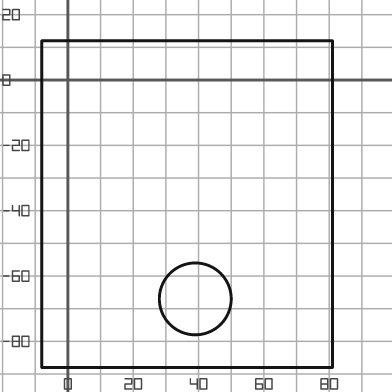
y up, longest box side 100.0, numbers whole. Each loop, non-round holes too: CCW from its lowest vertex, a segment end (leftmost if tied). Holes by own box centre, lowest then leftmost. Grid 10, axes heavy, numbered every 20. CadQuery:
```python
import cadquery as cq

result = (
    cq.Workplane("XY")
    .moveTo(-8.0, -88.0)
    .lineTo(81.0, -88.0)
    .lineTo(81.0, 12.0)
    .lineTo(-8.0, 12.0)
    .close()
    .moveTo(39.0, -67.0)
    .circle(11.0)
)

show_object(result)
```